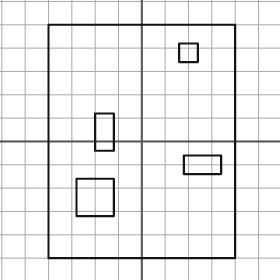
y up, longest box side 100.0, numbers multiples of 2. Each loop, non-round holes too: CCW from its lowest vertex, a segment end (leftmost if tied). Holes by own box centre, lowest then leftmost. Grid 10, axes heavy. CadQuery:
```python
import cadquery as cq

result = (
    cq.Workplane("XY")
    .moveTo(-40.0, -50.0)
    .lineTo(40.0, -50.0)
    .lineTo(40.0, 50.0)
    .lineTo(-40.0, 50.0)
    .close()
    .moveTo(-28.0, -32.0)
    .lineTo(-12.0, -32.0)
    .lineTo(-12.0, -16.0)
    .lineTo(-28.0, -16.0)
    .close()
    .moveTo(18.0, -14.0)
    .lineTo(34.0, -14.0)
    .lineTo(34.0, -6.0)
    .lineTo(18.0, -6.0)
    .close()
    .moveTo(-20.0, -4.0)
    .lineTo(-12.0, -4.0)
    .lineTo(-12.0, 12.0)
    .lineTo(-20.0, 12.0)
    .close()
    .moveTo(16.0, 34.0)
    .lineTo(24.0, 34.0)
    .lineTo(24.0, 42.0)
    .lineTo(16.0, 42.0)
    .close()
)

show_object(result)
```